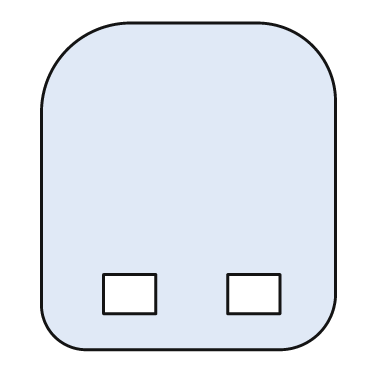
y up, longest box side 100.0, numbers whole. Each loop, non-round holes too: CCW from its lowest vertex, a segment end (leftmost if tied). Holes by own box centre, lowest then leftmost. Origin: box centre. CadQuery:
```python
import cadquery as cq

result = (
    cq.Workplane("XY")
    .moveTo(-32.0, -50.0)
    .lineTo(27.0, -50.0)
    .threePointArc((40.0, -45.0), (45.0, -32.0))
    .lineTo(45.0, 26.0)
    .threePointArc((38.0, 43.0), (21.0, 50.0))
    .lineTo(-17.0, 50.0)
    .threePointArc((-37.0, 42.0), (-45.0, 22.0))
    .lineTo(-45.0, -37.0)
    .threePointArc((-41.0, -46.0), (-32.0, -50.0))
    .close()
    .moveTo(-26.0, -39.0)
    .lineTo(-10.0, -39.0)
    .lineTo(-10.0, -27.0)
    .lineTo(-26.0, -27.0)
    .close()
    .moveTo(12.0, -39.0)
    .lineTo(28.0, -39.0)
    .lineTo(28.0, -27.0)
    .lineTo(12.0, -27.0)
    .close()
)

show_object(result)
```